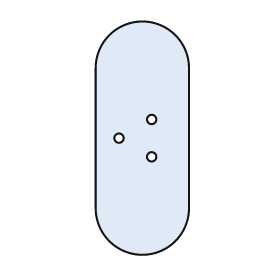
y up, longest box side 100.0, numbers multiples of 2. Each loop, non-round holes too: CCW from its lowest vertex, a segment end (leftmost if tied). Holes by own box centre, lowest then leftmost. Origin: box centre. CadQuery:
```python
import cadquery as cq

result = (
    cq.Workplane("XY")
    .moveTo(-20.0, -30.0)
    .threePointArc((0.0, -50.0), (20.0, -30.0))
    .lineTo(20.0, 30.0)
    .threePointArc((0.0, 50.0), (-20.0, 30.0))
    .close()
    .moveTo(4.0, -8.0)
    .circle(2.0)
    .moveTo(-10.0, 0.0)
    .circle(2.0)
    .moveTo(4.0, 8.0)
    .circle(2.0)
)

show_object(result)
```